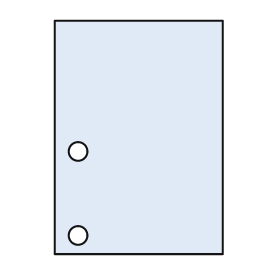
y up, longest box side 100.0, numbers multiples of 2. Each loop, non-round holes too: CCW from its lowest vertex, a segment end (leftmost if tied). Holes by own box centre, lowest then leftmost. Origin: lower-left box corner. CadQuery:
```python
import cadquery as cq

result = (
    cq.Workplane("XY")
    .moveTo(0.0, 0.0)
    .lineTo(72.0, 0.0)
    .lineTo(72.0, 100.0)
    .lineTo(0.0, 100.0)
    .close()
    .moveTo(10.0, 8.0)
    .circle(4.0)
    .moveTo(10.0, 44.0)
    .circle(4.0)
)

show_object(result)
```